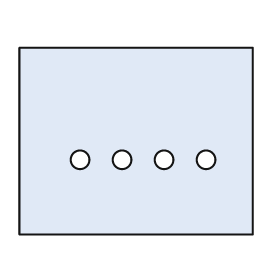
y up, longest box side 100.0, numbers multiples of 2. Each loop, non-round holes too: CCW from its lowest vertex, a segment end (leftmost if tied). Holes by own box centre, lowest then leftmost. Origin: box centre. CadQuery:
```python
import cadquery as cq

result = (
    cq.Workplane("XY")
    .moveTo(-50.0, -40.0)
    .lineTo(50.0, -40.0)
    .lineTo(50.0, 40.0)
    .lineTo(-50.0, 40.0)
    .close()
    .moveTo(-24.0, -8.0)
    .circle(4.0)
    .moveTo(-6.0, -8.0)
    .circle(4.0)
    .moveTo(12.0, -8.0)
    .circle(4.0)
    .moveTo(30.0, -8.0)
    .circle(4.0)
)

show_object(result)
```